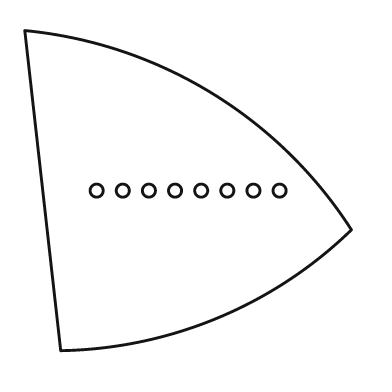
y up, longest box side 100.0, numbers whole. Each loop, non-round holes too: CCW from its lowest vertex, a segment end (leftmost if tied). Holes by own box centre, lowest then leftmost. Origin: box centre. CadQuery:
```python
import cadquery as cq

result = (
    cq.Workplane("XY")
    .moveTo(-39.0, -49.0)
    .threePointArc((9.0, -39.0), (50.0, -12.0))
    .threePointArc((7.0, 30.0), (-50.0, 49.0))
    .close()
    .moveTo(-28.0, 0.0)
    .circle(2.0)
    .moveTo(-20.0, 0.0)
    .circle(2.0)
    .moveTo(-12.0, 0.0)
    .circle(2.0)
    .moveTo(-4.0, 0.0)
    .circle(2.0)
    .moveTo(4.0, 0.0)
    .circle(2.0)
    .moveTo(12.0, 0.0)
    .circle(2.0)
    .moveTo(20.0, 0.0)
    .circle(2.0)
    .moveTo(28.0, 0.0)
    .circle(2.0)
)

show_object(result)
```